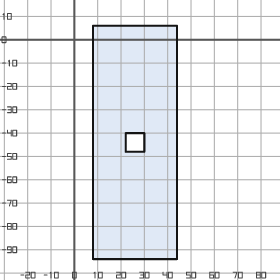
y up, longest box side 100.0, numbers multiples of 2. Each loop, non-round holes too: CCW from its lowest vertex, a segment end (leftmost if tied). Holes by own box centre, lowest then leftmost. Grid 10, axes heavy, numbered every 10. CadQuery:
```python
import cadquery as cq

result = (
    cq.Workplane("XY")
    .moveTo(8.0, -94.0)
    .lineTo(44.0, -94.0)
    .lineTo(44.0, 6.0)
    .lineTo(8.0, 6.0)
    .close()
    .moveTo(22.0, -48.0)
    .lineTo(30.0, -48.0)
    .lineTo(30.0, -40.0)
    .lineTo(22.0, -40.0)
    .close()
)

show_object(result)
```